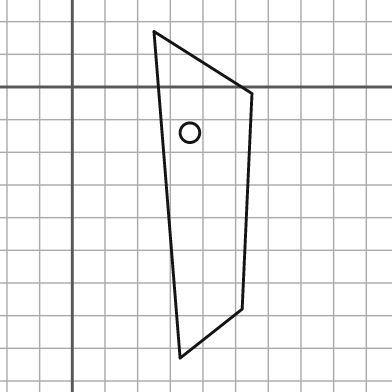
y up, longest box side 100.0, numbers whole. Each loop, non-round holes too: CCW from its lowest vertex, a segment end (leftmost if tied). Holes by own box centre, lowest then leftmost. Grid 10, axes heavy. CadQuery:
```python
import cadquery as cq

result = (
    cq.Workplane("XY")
    .moveTo(33.0, -83.0)
    .lineTo(52.0, -68.0)
    .lineTo(55.0, -2.0)
    .lineTo(25.0, 17.0)
    .close()
    .moveTo(36.0, -14.0)
    .circle(3.0)
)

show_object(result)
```